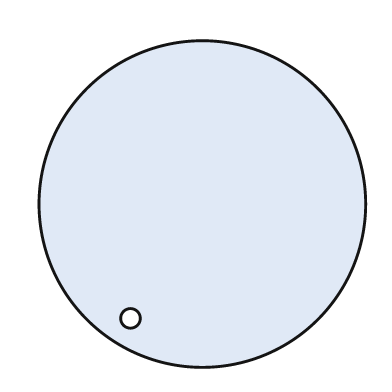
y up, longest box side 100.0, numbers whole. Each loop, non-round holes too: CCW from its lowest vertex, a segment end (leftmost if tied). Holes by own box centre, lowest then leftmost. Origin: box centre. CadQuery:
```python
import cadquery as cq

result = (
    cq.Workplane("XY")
    .moveTo(0.0, 0.0)
    .circle(50.0)
    .moveTo(-22.0, -35.0)
    .circle(3.0)
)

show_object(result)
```